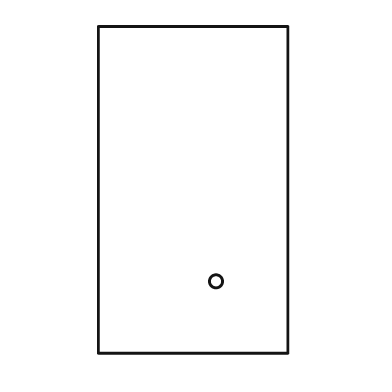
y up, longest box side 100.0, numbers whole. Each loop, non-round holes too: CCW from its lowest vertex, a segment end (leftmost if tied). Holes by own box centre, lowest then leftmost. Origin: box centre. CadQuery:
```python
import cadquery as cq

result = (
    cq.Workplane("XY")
    .moveTo(-29.0, -50.0)
    .lineTo(29.0, -50.0)
    .lineTo(29.0, 50.0)
    .lineTo(-29.0, 50.0)
    .close()
    .moveTo(7.0, -28.0)
    .circle(2.0)
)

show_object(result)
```